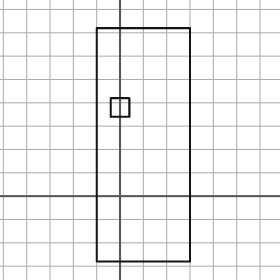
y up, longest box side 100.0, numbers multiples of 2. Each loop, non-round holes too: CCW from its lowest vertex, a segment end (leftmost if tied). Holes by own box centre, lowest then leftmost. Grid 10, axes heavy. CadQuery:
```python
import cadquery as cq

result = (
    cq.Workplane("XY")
    .moveTo(-10.0, -28.0)
    .lineTo(30.0, -28.0)
    .lineTo(30.0, 72.0)
    .lineTo(-10.0, 72.0)
    .close()
    .moveTo(-4.0, 34.0)
    .lineTo(4.0, 34.0)
    .lineTo(4.0, 42.0)
    .lineTo(-4.0, 42.0)
    .close()
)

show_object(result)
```